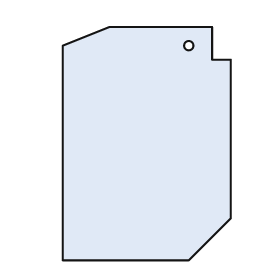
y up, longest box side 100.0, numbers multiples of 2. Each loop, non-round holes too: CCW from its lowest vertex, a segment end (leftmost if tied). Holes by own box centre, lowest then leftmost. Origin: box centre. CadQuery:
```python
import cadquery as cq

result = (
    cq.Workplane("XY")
    .moveTo(-36.0, -50.0)
    .lineTo(18.0, -50.0)
    .lineTo(36.0, -32.0)
    .lineTo(36.0, 36.0)
    .lineTo(28.0, 36.0)
    .lineTo(28.0, 50.0)
    .lineTo(-16.0, 50.0)
    .lineTo(-36.0, 42.0)
    .close()
    .moveTo(18.0, 42.0)
    .circle(2.0)
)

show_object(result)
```